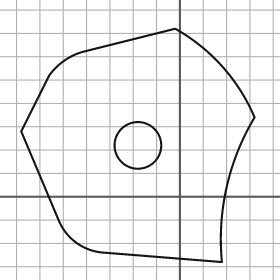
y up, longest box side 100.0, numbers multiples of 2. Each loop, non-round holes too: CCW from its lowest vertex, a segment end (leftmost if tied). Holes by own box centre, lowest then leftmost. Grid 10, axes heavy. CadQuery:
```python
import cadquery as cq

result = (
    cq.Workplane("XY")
    .moveTo(18.0, -28.0)
    .threePointArc((20.0, 4.0), (32.0, 34.0))
    .threePointArc((18.0, 56.0), (-2.0, 72.0))
    .lineTo(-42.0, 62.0)
    .threePointArc((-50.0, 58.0), (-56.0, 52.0))
    .lineTo(-68.0, 28.0)
    .lineTo(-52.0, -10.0)
    .threePointArc((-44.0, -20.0), (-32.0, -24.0))
    .close()
    .moveTo(-18.0, 22.0)
    .circle(10.0)
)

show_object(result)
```